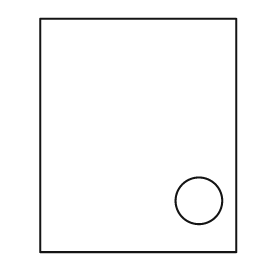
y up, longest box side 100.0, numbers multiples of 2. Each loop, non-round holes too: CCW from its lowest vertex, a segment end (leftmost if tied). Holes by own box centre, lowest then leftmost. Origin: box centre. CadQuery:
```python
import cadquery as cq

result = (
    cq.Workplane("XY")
    .moveTo(-42.0, -50.0)
    .lineTo(42.0, -50.0)
    .lineTo(42.0, 50.0)
    .lineTo(-42.0, 50.0)
    .close()
    .moveTo(26.0, -28.0)
    .circle(10.0)
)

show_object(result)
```